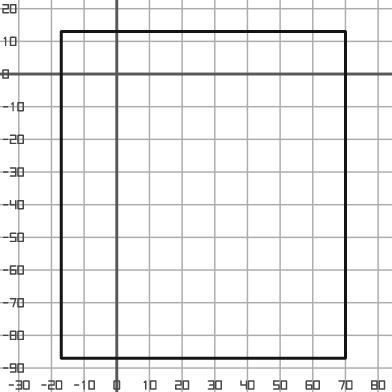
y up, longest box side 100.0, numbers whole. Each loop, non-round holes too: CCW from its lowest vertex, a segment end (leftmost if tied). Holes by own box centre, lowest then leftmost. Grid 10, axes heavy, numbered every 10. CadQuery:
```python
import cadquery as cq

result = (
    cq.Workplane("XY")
    .moveTo(-17.0, -87.0)
    .lineTo(70.0, -87.0)
    .lineTo(70.0, 13.0)
    .lineTo(-17.0, 13.0)
    .close()
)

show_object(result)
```